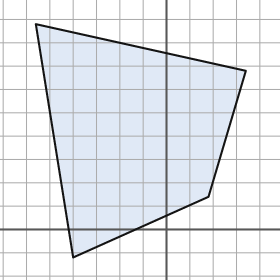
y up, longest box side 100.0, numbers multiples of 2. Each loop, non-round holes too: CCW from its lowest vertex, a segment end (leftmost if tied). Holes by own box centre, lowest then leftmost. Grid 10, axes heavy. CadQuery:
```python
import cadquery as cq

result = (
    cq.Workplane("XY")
    .moveTo(-40.0, -12.0)
    .lineTo(18.0, 14.0)
    .lineTo(34.0, 68.0)
    .lineTo(-56.0, 88.0)
    .close()
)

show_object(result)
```